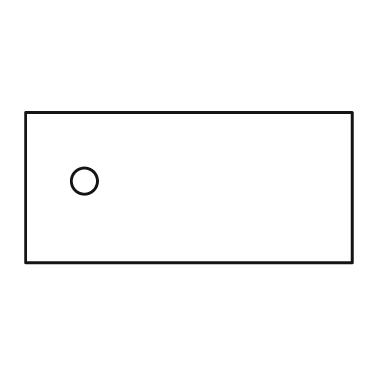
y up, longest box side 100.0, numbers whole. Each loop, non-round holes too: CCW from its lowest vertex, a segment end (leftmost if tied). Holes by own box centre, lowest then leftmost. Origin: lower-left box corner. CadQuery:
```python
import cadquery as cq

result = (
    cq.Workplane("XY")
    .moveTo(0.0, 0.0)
    .lineTo(100.0, 0.0)
    .lineTo(100.0, 46.0)
    .lineTo(0.0, 46.0)
    .close()
    .moveTo(18.0, 25.0)
    .circle(4.0)
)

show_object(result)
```